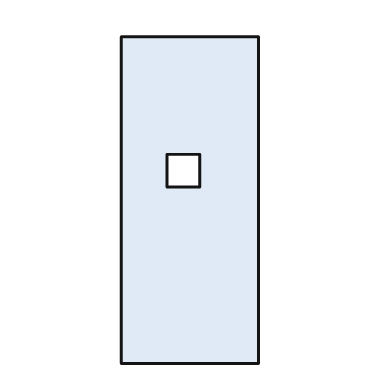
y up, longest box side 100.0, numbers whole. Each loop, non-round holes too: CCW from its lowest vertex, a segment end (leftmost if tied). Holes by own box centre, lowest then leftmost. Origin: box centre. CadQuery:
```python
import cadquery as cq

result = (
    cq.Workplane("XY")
    .moveTo(-21.0, -50.0)
    .lineTo(21.0, -50.0)
    .lineTo(21.0, 50.0)
    .lineTo(-21.0, 50.0)
    .close()
    .moveTo(-7.0, 4.0)
    .lineTo(3.0, 4.0)
    .lineTo(3.0, 14.0)
    .lineTo(-7.0, 14.0)
    .close()
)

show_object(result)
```